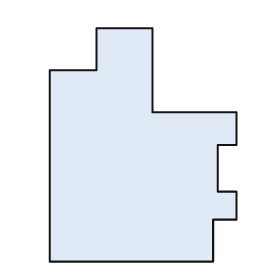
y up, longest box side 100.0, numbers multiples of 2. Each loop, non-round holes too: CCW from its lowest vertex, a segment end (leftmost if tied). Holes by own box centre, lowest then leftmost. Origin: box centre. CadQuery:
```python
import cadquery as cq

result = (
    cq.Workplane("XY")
    .moveTo(-40.0, -50.0)
    .lineTo(30.0, -50.0)
    .lineTo(30.0, -32.0)
    .lineTo(40.0, -32.0)
    .lineTo(40.0, -20.0)
    .lineTo(32.0, -20.0)
    .lineTo(32.0, 0.0)
    .lineTo(40.0, 0.0)
    .lineTo(40.0, 14.0)
    .lineTo(4.0, 14.0)
    .lineTo(4.0, 50.0)
    .lineTo(-20.0, 50.0)
    .lineTo(-20.0, 32.0)
    .lineTo(-40.0, 32.0)
    .close()
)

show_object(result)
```